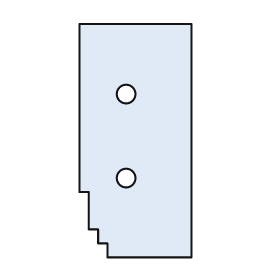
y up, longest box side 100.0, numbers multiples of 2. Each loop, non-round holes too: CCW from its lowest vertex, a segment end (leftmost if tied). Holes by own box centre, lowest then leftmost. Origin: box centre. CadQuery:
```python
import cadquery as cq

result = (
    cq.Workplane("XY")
    .moveTo(-12.0, -50.0)
    .lineTo(24.0, -50.0)
    .lineTo(24.0, 50.0)
    .lineTo(-24.0, 50.0)
    .lineTo(-24.0, -22.0)
    .lineTo(-20.0, -22.0)
    .lineTo(-20.0, -38.0)
    .lineTo(-16.0, -38.0)
    .lineTo(-16.0, -44.0)
    .lineTo(-12.0, -44.0)
    .close()
    .moveTo(-4.0, -16.0)
    .circle(4.0)
    .moveTo(-4.0, 20.0)
    .circle(4.0)
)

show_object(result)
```